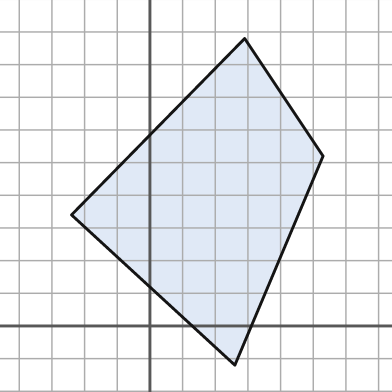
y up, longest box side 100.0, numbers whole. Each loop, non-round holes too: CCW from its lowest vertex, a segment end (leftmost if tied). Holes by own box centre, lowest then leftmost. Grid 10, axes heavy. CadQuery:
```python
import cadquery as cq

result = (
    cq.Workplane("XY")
    .moveTo(26.0, -12.0)
    .lineTo(53.0, 52.0)
    .lineTo(29.0, 88.0)
    .lineTo(-24.0, 34.0)
    .close()
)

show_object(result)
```